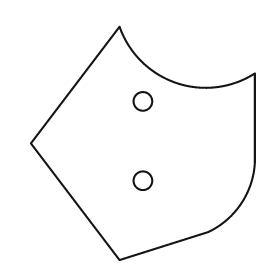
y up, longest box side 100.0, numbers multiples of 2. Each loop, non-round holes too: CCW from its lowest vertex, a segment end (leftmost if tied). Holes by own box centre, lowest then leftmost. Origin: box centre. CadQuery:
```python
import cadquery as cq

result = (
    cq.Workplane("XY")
    .moveTo(-10.0, -50.0)
    .lineTo(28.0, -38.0)
    .threePointArc((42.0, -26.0), (48.0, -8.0))
    .lineTo(48.0, 30.0)
    .threePointArc((14.0, 26.0), (-10.0, 50.0))
    .lineTo(-48.0, 0.0)
    .close()
    .moveTo(0.0, -16.0)
    .circle(4.0)
    .moveTo(0.0, 18.0)
    .circle(4.0)
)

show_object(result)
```